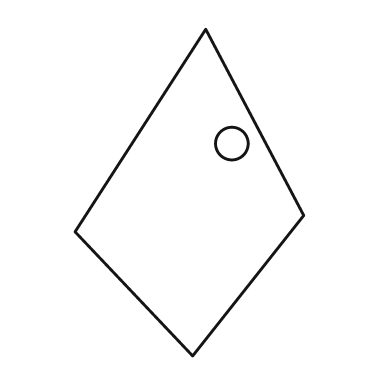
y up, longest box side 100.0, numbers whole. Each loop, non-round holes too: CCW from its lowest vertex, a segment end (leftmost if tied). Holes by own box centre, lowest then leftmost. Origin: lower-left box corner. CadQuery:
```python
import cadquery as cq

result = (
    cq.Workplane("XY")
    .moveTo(36.0, 0.0)
    .lineTo(70.0, 43.0)
    .lineTo(40.0, 100.0)
    .lineTo(0.0, 38.0)
    .close()
    .moveTo(48.0, 65.0)
    .circle(5.0)
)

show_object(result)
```